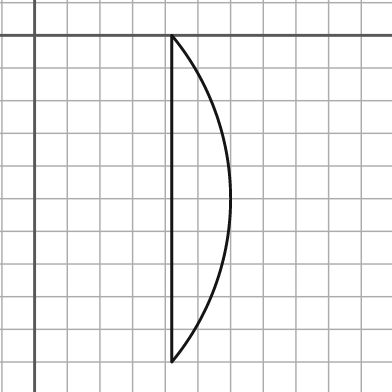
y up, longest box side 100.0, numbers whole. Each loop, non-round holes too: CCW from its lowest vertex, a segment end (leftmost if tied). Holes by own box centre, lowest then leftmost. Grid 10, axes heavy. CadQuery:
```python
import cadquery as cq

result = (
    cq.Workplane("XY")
    .moveTo(42.0, -100.0)
    .threePointArc((60.0, -50.0), (42.0, 0.0))
    .close()
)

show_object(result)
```